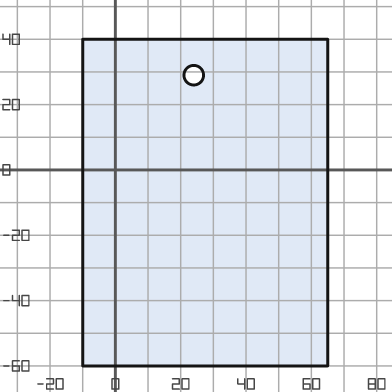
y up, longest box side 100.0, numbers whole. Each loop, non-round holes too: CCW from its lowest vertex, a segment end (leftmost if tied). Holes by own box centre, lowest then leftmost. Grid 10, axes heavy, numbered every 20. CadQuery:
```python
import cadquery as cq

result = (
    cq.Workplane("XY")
    .moveTo(-10.0, -60.0)
    .lineTo(65.0, -60.0)
    .lineTo(65.0, 40.0)
    .lineTo(-10.0, 40.0)
    .close()
    .moveTo(24.0, 29.0)
    .circle(3.0)
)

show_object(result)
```